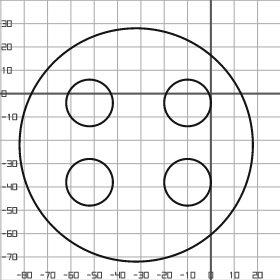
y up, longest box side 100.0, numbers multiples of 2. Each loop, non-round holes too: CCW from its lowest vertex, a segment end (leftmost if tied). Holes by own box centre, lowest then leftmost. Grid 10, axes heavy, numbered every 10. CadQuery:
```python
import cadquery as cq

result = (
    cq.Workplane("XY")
    .moveTo(-32.0, -22.0)
    .circle(50.0)
    .moveTo(-52.0, -38.0)
    .circle(10.0)
    .moveTo(-10.0, -38.0)
    .circle(10.0)
    .moveTo(-52.0, -4.0)
    .circle(10.0)
    .moveTo(-10.0, -4.0)
    .circle(10.0)
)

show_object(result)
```